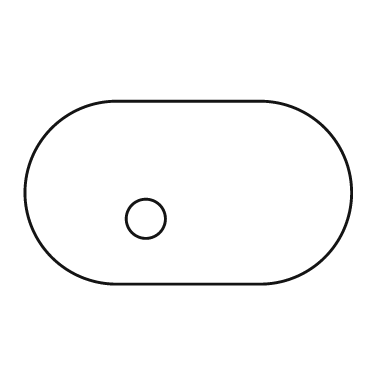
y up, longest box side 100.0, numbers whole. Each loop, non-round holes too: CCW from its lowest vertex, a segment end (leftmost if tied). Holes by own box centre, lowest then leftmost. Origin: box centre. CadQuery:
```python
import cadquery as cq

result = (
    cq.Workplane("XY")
    .moveTo(-22.0, -28.0)
    .lineTo(22.0, -28.0)
    .threePointArc((50.0, 0.0), (22.0, 28.0))
    .lineTo(-22.0, 28.0)
    .threePointArc((-50.0, 0.0), (-22.0, -28.0))
    .close()
    .moveTo(-13.0, -8.0)
    .circle(6.0)
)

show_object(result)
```